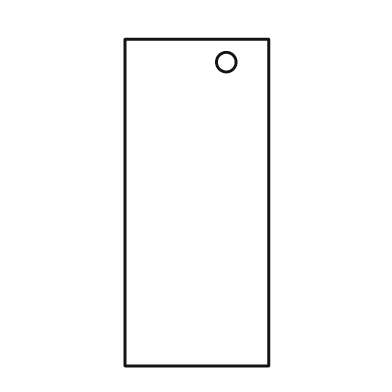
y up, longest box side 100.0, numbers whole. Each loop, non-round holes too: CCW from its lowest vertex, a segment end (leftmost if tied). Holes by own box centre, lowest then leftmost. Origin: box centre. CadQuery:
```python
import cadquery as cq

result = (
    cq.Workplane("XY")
    .moveTo(-22.0, -50.0)
    .lineTo(22.0, -50.0)
    .lineTo(22.0, 50.0)
    .lineTo(-22.0, 50.0)
    .close()
    .moveTo(9.0, 43.0)
    .circle(3.0)
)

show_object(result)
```